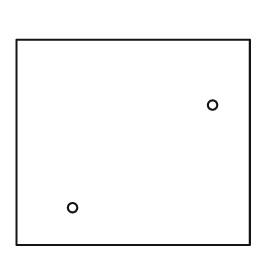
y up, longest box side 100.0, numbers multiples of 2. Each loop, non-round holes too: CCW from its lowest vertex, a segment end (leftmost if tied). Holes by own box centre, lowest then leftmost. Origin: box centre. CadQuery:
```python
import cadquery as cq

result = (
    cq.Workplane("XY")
    .moveTo(-50.0, -44.0)
    .lineTo(50.0, -44.0)
    .lineTo(50.0, 44.0)
    .lineTo(-50.0, 44.0)
    .close()
    .moveTo(-26.0, -28.0)
    .circle(2.0)
    .moveTo(34.0, 16.0)
    .circle(2.0)
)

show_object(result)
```